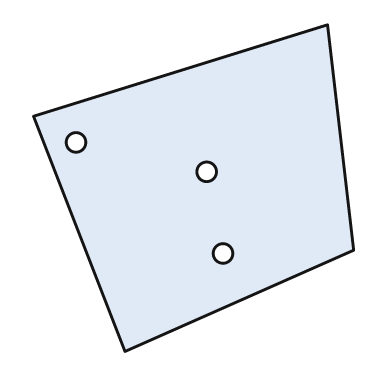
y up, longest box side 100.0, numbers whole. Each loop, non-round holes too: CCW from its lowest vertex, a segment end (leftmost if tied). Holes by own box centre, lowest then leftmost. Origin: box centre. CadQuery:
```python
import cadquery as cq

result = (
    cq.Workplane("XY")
    .moveTo(-21.0, -50.0)
    .lineTo(49.0, -19.0)
    .lineTo(41.0, 50.0)
    .lineTo(-49.0, 22.0)
    .close()
    .moveTo(9.0, -20.0)
    .circle(3.0)
    .moveTo(4.0, 5.0)
    .circle(3.0)
    .moveTo(-36.0, 14.0)
    .circle(3.0)
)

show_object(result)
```